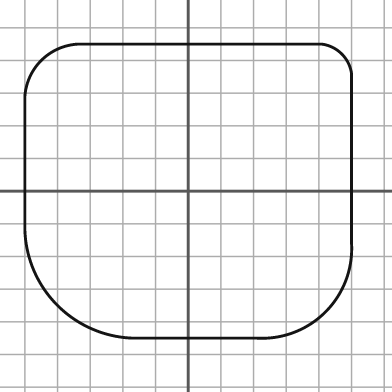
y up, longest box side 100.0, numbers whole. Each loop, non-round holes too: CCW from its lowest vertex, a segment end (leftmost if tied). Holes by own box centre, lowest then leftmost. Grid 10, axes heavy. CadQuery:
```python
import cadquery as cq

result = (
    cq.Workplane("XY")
    .moveTo(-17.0, -45.0)
    .lineTo(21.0, -45.0)
    .threePointArc((42.0, -37.0), (50.0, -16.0))
    .lineTo(50.0, 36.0)
    .threePointArc((47.0, 42.0), (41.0, 45.0))
    .lineTo(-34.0, 45.0)
    .threePointArc((-45.0, 40.0), (-50.0, 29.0))
    .lineTo(-50.0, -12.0)
    .threePointArc((-40.0, -35.0), (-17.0, -45.0))
    .close()
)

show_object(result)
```